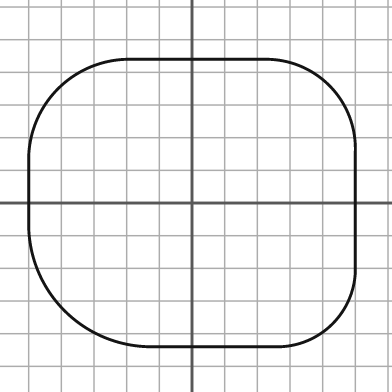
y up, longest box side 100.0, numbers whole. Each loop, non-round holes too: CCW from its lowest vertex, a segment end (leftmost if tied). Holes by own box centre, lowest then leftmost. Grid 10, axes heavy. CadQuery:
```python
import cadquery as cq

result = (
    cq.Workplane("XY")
    .moveTo(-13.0, -44.0)
    .lineTo(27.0, -44.0)
    .threePointArc((43.0, -37.0), (50.0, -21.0))
    .lineTo(50.0, 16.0)
    .threePointArc((42.0, 36.0), (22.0, 44.0))
    .lineTo(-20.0, 44.0)
    .threePointArc((-41.0, 35.0), (-50.0, 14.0))
    .lineTo(-50.0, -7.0)
    .threePointArc((-39.0, -33.0), (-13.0, -44.0))
    .close()
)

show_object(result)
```